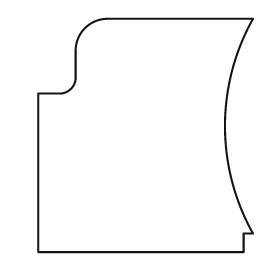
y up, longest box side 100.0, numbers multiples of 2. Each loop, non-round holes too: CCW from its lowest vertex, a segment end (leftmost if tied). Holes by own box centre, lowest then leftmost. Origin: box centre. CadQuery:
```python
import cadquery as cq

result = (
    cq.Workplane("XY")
    .moveTo(-46.0, -50.0)
    .lineTo(42.0, -50.0)
    .lineTo(42.0, -42.0)
    .lineTo(46.0, -42.0)
    .threePointArc((34.0, 4.0), (46.0, 50.0))
    .lineTo(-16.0, 50.0)
    .threePointArc((-26.0, 46.0), (-30.0, 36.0))
    .lineTo(-30.0, 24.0)
    .threePointArc((-32.0, 20.0), (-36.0, 18.0))
    .lineTo(-46.0, 18.0)
    .close()
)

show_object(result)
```